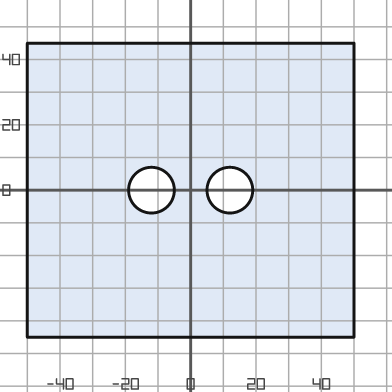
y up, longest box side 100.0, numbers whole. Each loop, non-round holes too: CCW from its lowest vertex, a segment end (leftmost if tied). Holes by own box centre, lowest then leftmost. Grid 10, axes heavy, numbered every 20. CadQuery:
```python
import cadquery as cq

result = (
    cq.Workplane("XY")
    .moveTo(-50.0, -45.0)
    .lineTo(50.0, -45.0)
    .lineTo(50.0, 45.0)
    .lineTo(-50.0, 45.0)
    .close()
    .moveTo(-12.0, 0.0)
    .circle(7.0)
    .moveTo(12.0, 0.0)
    .circle(7.0)
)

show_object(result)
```